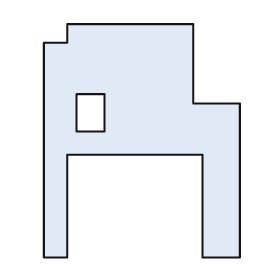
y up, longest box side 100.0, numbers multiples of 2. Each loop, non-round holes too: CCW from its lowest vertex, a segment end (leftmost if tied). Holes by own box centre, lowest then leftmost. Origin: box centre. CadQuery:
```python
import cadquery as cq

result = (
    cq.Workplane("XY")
    .moveTo(-42.0, -50.0)
    .lineTo(-32.0, -50.0)
    .lineTo(-32.0, -6.0)
    .lineTo(26.0, -6.0)
    .lineTo(26.0, -50.0)
    .lineTo(42.0, -50.0)
    .lineTo(42.0, 16.0)
    .lineTo(22.0, 16.0)
    .lineTo(22.0, 50.0)
    .lineTo(-32.0, 50.0)
    .lineTo(-32.0, 42.0)
    .lineTo(-42.0, 42.0)
    .close()
    .moveTo(-28.0, 4.0)
    .lineTo(-16.0, 4.0)
    .lineTo(-16.0, 20.0)
    .lineTo(-28.0, 20.0)
    .close()
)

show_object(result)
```